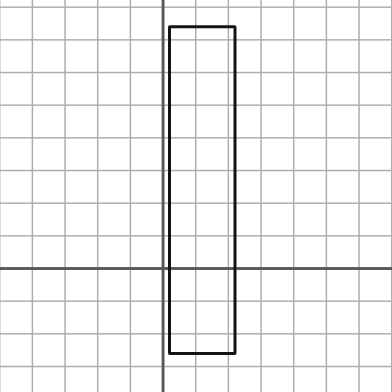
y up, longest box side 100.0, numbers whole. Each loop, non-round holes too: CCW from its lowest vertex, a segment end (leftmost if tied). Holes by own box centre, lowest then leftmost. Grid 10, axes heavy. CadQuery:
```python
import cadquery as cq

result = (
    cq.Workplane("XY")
    .moveTo(2.0, -26.0)
    .lineTo(22.0, -26.0)
    .lineTo(22.0, 74.0)
    .lineTo(2.0, 74.0)
    .close()
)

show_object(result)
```